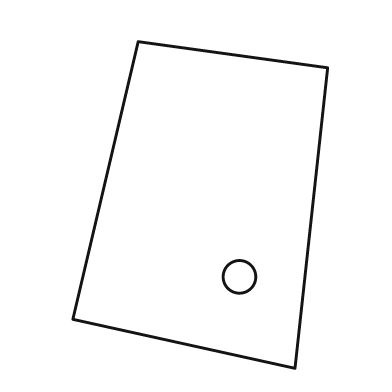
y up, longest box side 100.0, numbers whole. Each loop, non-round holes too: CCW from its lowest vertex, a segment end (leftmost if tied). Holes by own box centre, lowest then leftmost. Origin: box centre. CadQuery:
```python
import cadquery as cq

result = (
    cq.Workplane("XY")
    .moveTo(29.0, -50.0)
    .lineTo(39.0, 42.0)
    .lineTo(-19.0, 50.0)
    .lineTo(-39.0, -35.0)
    .close()
    .moveTo(12.0, -22.0)
    .circle(5.0)
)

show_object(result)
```